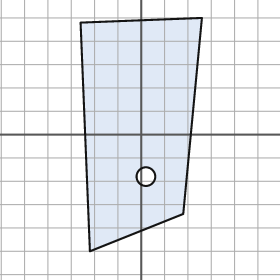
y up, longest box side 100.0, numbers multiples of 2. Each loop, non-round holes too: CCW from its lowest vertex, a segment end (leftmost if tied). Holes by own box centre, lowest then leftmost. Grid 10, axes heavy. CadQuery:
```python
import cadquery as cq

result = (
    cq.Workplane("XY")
    .moveTo(-22.0, -50.0)
    .lineTo(18.0, -34.0)
    .lineTo(26.0, 50.0)
    .lineTo(-26.0, 48.0)
    .close()
    .moveTo(2.0, -18.0)
    .circle(4.0)
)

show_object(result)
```